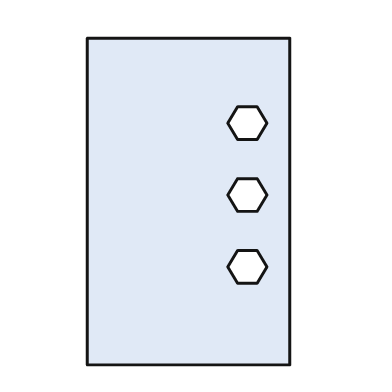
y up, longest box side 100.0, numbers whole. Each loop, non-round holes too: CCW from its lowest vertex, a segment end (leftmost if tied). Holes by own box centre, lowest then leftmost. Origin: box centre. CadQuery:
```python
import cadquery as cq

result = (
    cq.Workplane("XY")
    .moveTo(-31.0, -50.0)
    .lineTo(31.0, -50.0)
    .lineTo(31.0, 50.0)
    .lineTo(-31.0, 50.0)
    .close()
    .moveTo(15.0, -25.0)
    .lineTo(21.0, -25.0)
    .lineTo(24.0, -20.0)
    .lineTo(21.0, -15.0)
    .lineTo(15.0, -15.0)
    .lineTo(12.0, -20.0)
    .close()
    .moveTo(15.0, -3.0)
    .lineTo(21.0, -3.0)
    .lineTo(24.0, 2.0)
    .lineTo(21.0, 7.0)
    .lineTo(15.0, 7.0)
    .lineTo(12.0, 2.0)
    .close()
    .moveTo(15.0, 19.0)
    .lineTo(21.0, 19.0)
    .lineTo(24.0, 24.0)
    .lineTo(21.0, 29.0)
    .lineTo(15.0, 29.0)
    .lineTo(12.0, 24.0)
    .close()
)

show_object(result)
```